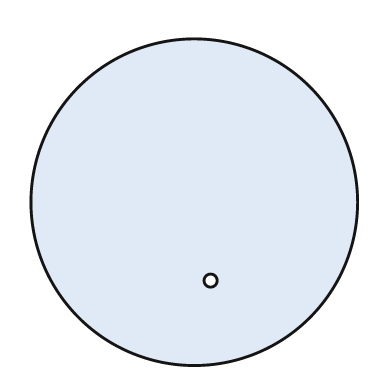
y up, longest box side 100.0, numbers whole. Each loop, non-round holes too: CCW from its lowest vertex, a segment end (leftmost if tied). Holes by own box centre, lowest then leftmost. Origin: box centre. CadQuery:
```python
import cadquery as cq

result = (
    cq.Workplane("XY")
    .moveTo(0.0, 0.0)
    .circle(50.0)
    .moveTo(5.0, -24.0)
    .circle(2.0)
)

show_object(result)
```